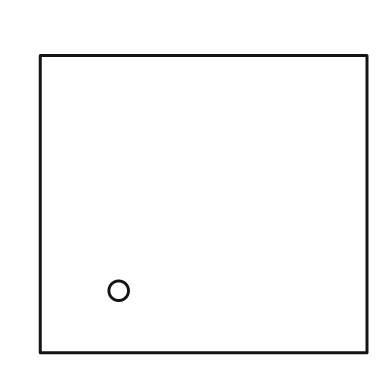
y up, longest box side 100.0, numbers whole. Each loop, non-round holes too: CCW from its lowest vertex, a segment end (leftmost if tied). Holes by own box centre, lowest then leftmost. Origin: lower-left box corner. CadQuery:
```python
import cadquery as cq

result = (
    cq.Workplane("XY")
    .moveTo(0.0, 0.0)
    .lineTo(100.0, 0.0)
    .lineTo(100.0, 91.0)
    .lineTo(0.0, 91.0)
    .close()
    .moveTo(24.0, 19.0)
    .circle(3.0)
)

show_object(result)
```